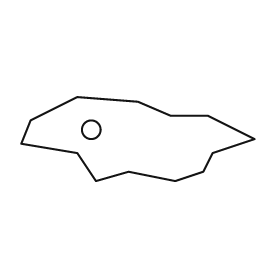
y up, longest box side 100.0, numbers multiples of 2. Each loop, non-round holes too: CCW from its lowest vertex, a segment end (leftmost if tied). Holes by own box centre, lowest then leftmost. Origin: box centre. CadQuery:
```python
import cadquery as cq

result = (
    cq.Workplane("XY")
    .moveTo(-18.0, -18.0)
    .lineTo(-4.0, -14.0)
    .lineTo(16.0, -18.0)
    .lineTo(28.0, -14.0)
    .lineTo(32.0, -6.0)
    .lineTo(50.0, 0.0)
    .lineTo(30.0, 10.0)
    .lineTo(14.0, 10.0)
    .lineTo(0.0, 16.0)
    .lineTo(-26.0, 18.0)
    .lineTo(-46.0, 8.0)
    .lineTo(-50.0, -2.0)
    .lineTo(-26.0, -6.0)
    .close()
    .moveTo(-20.0, 4.0)
    .circle(4.0)
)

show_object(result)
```